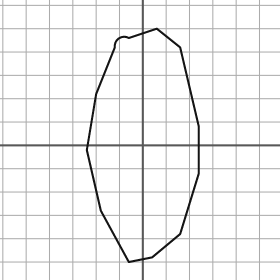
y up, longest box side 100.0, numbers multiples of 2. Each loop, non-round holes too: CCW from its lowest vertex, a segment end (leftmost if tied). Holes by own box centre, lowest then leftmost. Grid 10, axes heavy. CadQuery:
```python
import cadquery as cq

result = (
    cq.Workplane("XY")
    .moveTo(-6.0, -50.0)
    .lineTo(4.0, -48.0)
    .lineTo(16.0, -38.0)
    .lineTo(24.0, -12.0)
    .lineTo(24.0, 8.0)
    .lineTo(16.0, 42.0)
    .lineTo(6.0, 50.0)
    .lineTo(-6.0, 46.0)
    .threePointArc((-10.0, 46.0), (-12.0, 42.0))
    .lineTo(-20.0, 22.0)
    .lineTo(-24.0, -2.0)
    .lineTo(-18.0, -28.0)
    .close()
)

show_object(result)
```